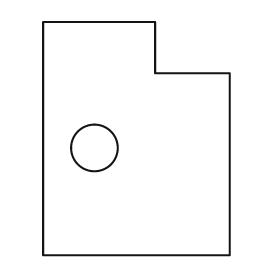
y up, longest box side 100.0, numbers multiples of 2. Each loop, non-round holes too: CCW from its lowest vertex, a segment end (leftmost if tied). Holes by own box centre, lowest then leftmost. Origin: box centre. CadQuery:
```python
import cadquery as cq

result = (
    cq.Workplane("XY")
    .moveTo(-40.0, -50.0)
    .lineTo(40.0, -50.0)
    .lineTo(40.0, 28.0)
    .lineTo(8.0, 28.0)
    .lineTo(8.0, 50.0)
    .lineTo(-40.0, 50.0)
    .close()
    .moveTo(-18.0, -4.0)
    .circle(10.0)
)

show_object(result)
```